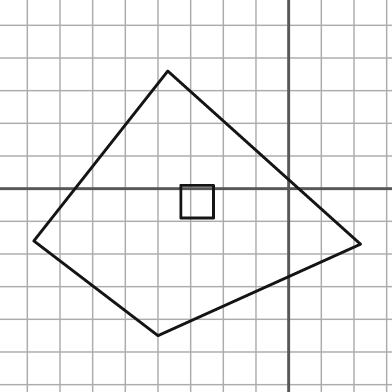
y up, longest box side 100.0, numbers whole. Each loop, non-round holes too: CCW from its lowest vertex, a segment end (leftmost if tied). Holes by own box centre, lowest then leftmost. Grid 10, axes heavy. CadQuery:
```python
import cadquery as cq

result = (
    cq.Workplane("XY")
    .moveTo(-40.0, -45.0)
    .lineTo(22.0, -17.0)
    .lineTo(-37.0, 36.0)
    .lineTo(-78.0, -16.0)
    .close()
    .moveTo(-33.0, -9.0)
    .lineTo(-23.0, -9.0)
    .lineTo(-23.0, 1.0)
    .lineTo(-33.0, 1.0)
    .close()
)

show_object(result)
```